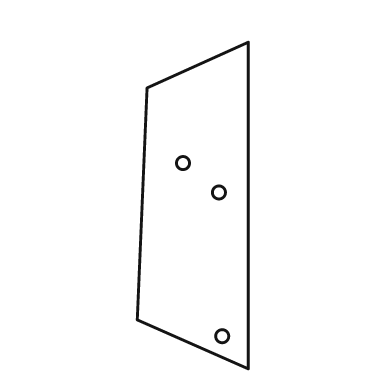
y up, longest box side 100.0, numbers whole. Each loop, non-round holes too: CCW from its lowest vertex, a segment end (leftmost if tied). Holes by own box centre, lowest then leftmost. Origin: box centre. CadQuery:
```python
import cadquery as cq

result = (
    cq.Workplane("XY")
    .moveTo(17.0, -50.0)
    .lineTo(17.0, 50.0)
    .lineTo(-14.0, 36.0)
    .lineTo(-17.0, -35.0)
    .close()
    .moveTo(9.0, -40.0)
    .circle(2.0)
    .moveTo(8.0, 4.0)
    .circle(2.0)
    .moveTo(-3.0, 13.0)
    .circle(2.0)
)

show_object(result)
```